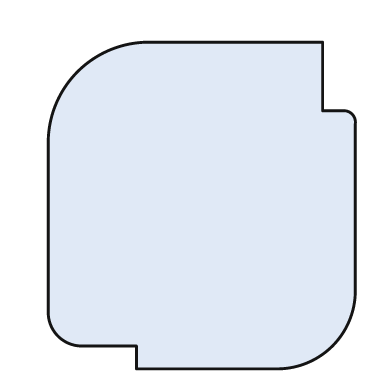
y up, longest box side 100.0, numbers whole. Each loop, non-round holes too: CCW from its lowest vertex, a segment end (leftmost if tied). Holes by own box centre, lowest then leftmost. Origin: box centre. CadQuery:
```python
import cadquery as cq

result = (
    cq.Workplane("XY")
    .moveTo(-20.0, -50.0)
    .lineTo(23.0, -50.0)
    .threePointArc((40.0, -43.0), (47.0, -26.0))
    .lineTo(47.0, 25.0)
    .threePointArc((46.0, 28.0), (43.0, 29.0))
    .lineTo(37.0, 29.0)
    .lineTo(37.0, 50.0)
    .lineTo(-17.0, 50.0)
    .threePointArc((-38.0, 41.0), (-47.0, 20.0))
    .lineTo(-47.0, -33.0)
    .threePointArc((-44.0, -40.0), (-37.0, -43.0))
    .lineTo(-20.0, -43.0)
    .close()
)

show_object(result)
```